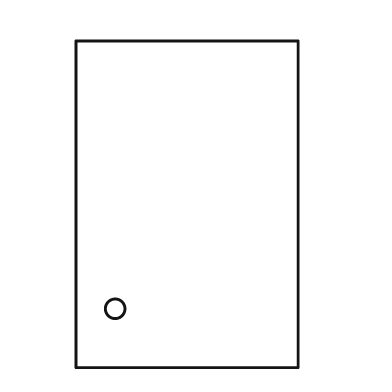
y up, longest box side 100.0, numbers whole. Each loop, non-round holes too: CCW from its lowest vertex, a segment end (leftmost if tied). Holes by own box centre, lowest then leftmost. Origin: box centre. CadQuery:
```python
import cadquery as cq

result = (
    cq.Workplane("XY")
    .moveTo(-34.0, -50.0)
    .lineTo(34.0, -50.0)
    .lineTo(34.0, 50.0)
    .lineTo(-34.0, 50.0)
    .close()
    .moveTo(-22.0, -32.0)
    .circle(3.0)
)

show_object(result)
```